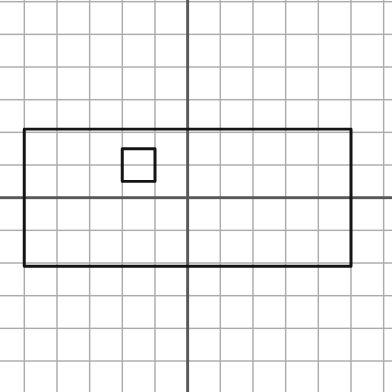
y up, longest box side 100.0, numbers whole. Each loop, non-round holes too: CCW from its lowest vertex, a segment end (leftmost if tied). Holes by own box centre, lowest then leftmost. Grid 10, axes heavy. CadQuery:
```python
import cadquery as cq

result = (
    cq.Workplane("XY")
    .moveTo(-50.0, -21.0)
    .lineTo(50.0, -21.0)
    .lineTo(50.0, 21.0)
    .lineTo(-50.0, 21.0)
    .close()
    .moveTo(-20.0, 5.0)
    .lineTo(-10.0, 5.0)
    .lineTo(-10.0, 15.0)
    .lineTo(-20.0, 15.0)
    .close()
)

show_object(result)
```